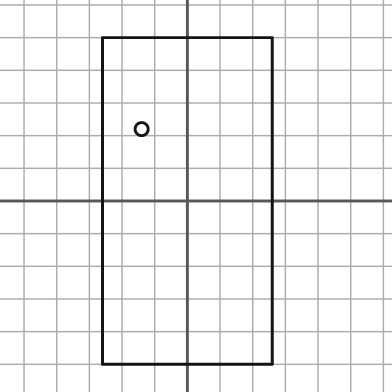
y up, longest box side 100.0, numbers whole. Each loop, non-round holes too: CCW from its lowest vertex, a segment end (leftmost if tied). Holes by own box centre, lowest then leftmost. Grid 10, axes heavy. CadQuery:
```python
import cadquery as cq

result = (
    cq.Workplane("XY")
    .moveTo(-26.0, -50.0)
    .lineTo(26.0, -50.0)
    .lineTo(26.0, 50.0)
    .lineTo(-26.0, 50.0)
    .close()
    .moveTo(-14.0, 22.0)
    .circle(2.0)
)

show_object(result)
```